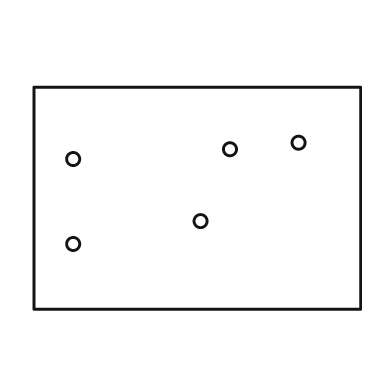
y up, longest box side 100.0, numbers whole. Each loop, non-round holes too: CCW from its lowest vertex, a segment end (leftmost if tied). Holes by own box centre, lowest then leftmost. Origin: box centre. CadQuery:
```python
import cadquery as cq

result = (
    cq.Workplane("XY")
    .moveTo(-50.0, -34.0)
    .lineTo(50.0, -34.0)
    .lineTo(50.0, 34.0)
    .lineTo(-50.0, 34.0)
    .close()
    .moveTo(-38.0, -14.0)
    .circle(2.0)
    .moveTo(1.0, -7.0)
    .circle(2.0)
    .moveTo(-38.0, 12.0)
    .circle(2.0)
    .moveTo(10.0, 15.0)
    .circle(2.0)
    .moveTo(31.0, 17.0)
    .circle(2.0)
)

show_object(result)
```